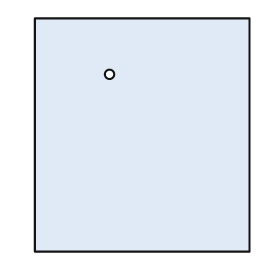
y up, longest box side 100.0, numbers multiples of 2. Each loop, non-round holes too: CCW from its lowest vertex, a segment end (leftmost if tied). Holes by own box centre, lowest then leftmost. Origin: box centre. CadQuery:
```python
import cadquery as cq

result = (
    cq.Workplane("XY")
    .moveTo(-46.0, -50.0)
    .lineTo(46.0, -50.0)
    .lineTo(46.0, 50.0)
    .lineTo(-46.0, 50.0)
    .close()
    .moveTo(-14.0, 26.0)
    .circle(2.0)
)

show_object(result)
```